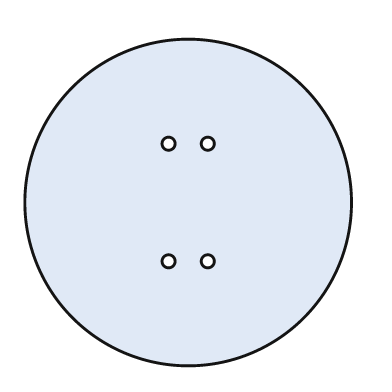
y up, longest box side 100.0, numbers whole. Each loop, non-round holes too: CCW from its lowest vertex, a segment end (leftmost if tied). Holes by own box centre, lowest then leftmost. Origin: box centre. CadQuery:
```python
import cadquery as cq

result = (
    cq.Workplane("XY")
    .moveTo(0.0, 0.0)
    .circle(50.0)
    .moveTo(-6.0, -18.0)
    .circle(2.0)
    .moveTo(6.0, -18.0)
    .circle(2.0)
    .moveTo(-6.0, 18.0)
    .circle(2.0)
    .moveTo(6.0, 18.0)
    .circle(2.0)
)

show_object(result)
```